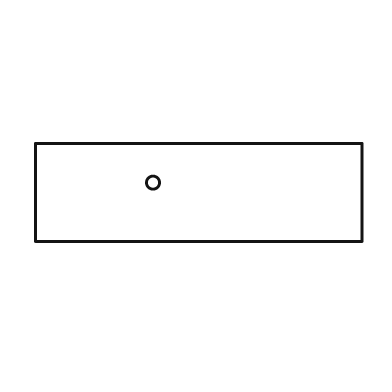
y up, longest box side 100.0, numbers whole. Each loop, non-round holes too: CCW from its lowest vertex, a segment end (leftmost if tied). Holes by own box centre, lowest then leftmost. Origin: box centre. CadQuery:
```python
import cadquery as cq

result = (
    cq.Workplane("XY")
    .moveTo(-50.0, -15.0)
    .lineTo(50.0, -15.0)
    .lineTo(50.0, 15.0)
    .lineTo(-50.0, 15.0)
    .close()
    .moveTo(-14.0, 3.0)
    .circle(2.0)
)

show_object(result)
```